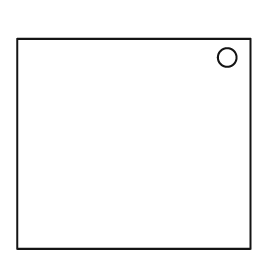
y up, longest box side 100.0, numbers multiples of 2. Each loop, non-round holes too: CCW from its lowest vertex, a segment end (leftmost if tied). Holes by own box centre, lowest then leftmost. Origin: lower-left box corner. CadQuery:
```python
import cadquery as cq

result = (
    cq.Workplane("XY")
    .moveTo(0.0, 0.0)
    .lineTo(100.0, 0.0)
    .lineTo(100.0, 90.0)
    .lineTo(0.0, 90.0)
    .close()
    .moveTo(90.0, 82.0)
    .circle(4.0)
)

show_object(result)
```